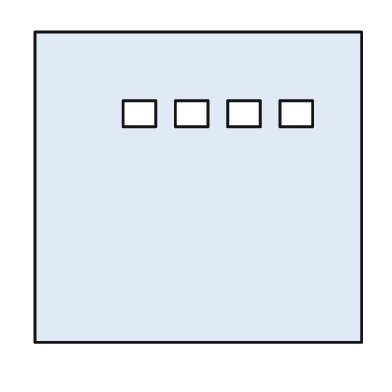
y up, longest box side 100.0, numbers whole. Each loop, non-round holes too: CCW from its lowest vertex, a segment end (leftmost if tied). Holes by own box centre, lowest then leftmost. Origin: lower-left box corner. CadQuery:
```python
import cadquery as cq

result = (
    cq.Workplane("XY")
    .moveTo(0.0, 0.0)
    .lineTo(100.0, 0.0)
    .lineTo(100.0, 95.0)
    .lineTo(0.0, 95.0)
    .close()
    .moveTo(27.0, 66.0)
    .lineTo(37.0, 66.0)
    .lineTo(37.0, 74.0)
    .lineTo(27.0, 74.0)
    .close()
    .moveTo(43.0, 66.0)
    .lineTo(53.0, 66.0)
    .lineTo(53.0, 74.0)
    .lineTo(43.0, 74.0)
    .close()
    .moveTo(59.0, 66.0)
    .lineTo(69.0, 66.0)
    .lineTo(69.0, 74.0)
    .lineTo(59.0, 74.0)
    .close()
    .moveTo(75.0, 66.0)
    .lineTo(85.0, 66.0)
    .lineTo(85.0, 74.0)
    .lineTo(75.0, 74.0)
    .close()
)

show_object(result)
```